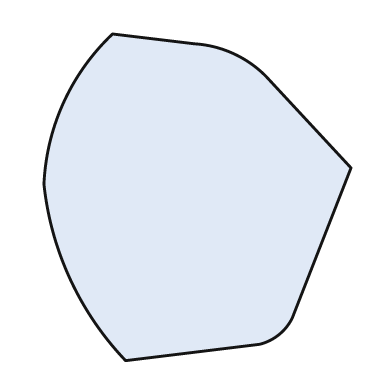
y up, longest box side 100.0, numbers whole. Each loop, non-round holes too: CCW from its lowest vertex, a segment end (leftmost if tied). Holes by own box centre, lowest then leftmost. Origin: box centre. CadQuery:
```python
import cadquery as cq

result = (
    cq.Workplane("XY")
    .moveTo(-22.0, -50.0)
    .lineTo(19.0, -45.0)
    .threePointArc((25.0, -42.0), (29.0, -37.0))
    .lineTo(47.0, 9.0)
    .lineTo(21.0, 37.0)
    .threePointArc((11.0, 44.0), (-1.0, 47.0))
    .lineTo(-26.0, 50.0)
    .threePointArc((-41.0, 29.0), (-47.0, 4.0))
    .threePointArc((-39.0, -25.0), (-22.0, -50.0))
    .close()
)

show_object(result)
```